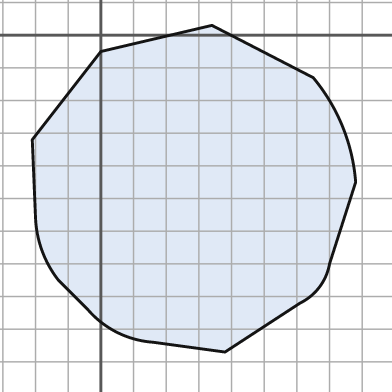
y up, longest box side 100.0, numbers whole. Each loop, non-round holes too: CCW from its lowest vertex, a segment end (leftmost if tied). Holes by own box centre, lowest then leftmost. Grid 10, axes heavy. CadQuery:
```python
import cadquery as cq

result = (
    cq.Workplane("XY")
    .moveTo(38.0, -97.0)
    .lineTo(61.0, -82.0)
    .threePointArc((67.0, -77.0), (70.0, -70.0))
    .lineTo(78.0, -45.0)
    .threePointArc((74.0, -28.0), (65.0, -13.0))
    .lineTo(34.0, 3.0)
    .lineTo(0.0, -5.0)
    .lineTo(-21.0, -32.0)
    .lineTo(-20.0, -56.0)
    .threePointArc((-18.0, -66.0), (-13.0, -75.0))
    .lineTo(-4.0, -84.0)
    .threePointArc((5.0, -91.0), (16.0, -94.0))
    .close()
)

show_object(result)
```